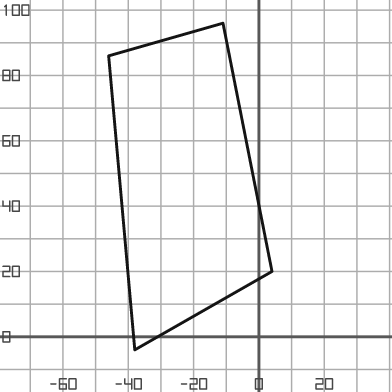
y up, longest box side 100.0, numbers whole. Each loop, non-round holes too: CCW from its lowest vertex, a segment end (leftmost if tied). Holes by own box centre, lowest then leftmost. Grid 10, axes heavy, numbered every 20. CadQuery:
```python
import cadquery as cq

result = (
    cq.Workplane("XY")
    .moveTo(-38.0, -4.0)
    .lineTo(4.0, 20.0)
    .lineTo(-11.0, 96.0)
    .lineTo(-46.0, 86.0)
    .close()
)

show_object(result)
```